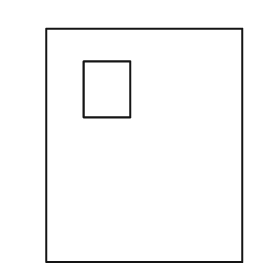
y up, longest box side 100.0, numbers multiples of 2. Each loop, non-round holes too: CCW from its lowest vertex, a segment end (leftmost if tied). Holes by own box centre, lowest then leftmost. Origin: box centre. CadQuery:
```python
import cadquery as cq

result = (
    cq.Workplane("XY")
    .moveTo(-42.0, -50.0)
    .lineTo(42.0, -50.0)
    .lineTo(42.0, 50.0)
    .lineTo(-42.0, 50.0)
    .close()
    .moveTo(-26.0, 12.0)
    .lineTo(-6.0, 12.0)
    .lineTo(-6.0, 36.0)
    .lineTo(-26.0, 36.0)
    .close()
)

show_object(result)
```